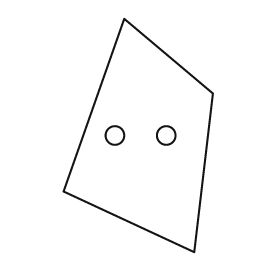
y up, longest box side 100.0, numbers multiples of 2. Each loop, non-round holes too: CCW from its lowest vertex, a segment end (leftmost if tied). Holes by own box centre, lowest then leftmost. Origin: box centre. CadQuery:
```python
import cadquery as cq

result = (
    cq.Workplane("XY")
    .moveTo(24.0, -50.0)
    .lineTo(32.0, 18.0)
    .lineTo(-6.0, 50.0)
    .lineTo(-32.0, -24.0)
    .close()
    .moveTo(-10.0, 0.0)
    .circle(4.0)
    .moveTo(12.0, 0.0)
    .circle(4.0)
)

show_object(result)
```